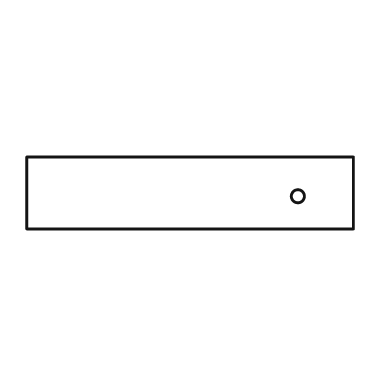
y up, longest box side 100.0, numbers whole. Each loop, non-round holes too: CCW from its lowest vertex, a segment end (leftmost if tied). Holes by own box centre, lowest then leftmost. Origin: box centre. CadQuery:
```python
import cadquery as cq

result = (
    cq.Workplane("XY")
    .moveTo(-50.0, -11.0)
    .lineTo(50.0, -11.0)
    .lineTo(50.0, 11.0)
    .lineTo(-50.0, 11.0)
    .close()
    .moveTo(33.0, -1.0)
    .circle(2.0)
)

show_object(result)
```